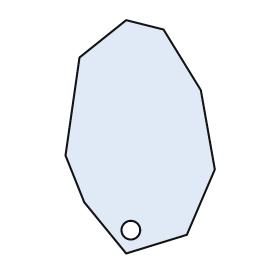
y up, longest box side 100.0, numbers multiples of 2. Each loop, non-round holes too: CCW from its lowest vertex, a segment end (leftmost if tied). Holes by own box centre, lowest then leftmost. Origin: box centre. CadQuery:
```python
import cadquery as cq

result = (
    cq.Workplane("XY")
    .moveTo(-6.0, -50.0)
    .lineTo(20.0, -42.0)
    .lineTo(32.0, -14.0)
    .lineTo(26.0, 20.0)
    .lineTo(10.0, 46.0)
    .lineTo(-6.0, 50.0)
    .lineTo(-26.0, 34.0)
    .lineTo(-32.0, -8.0)
    .lineTo(-24.0, -28.0)
    .close()
    .moveTo(-4.0, -40.0)
    .circle(4.0)
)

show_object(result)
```